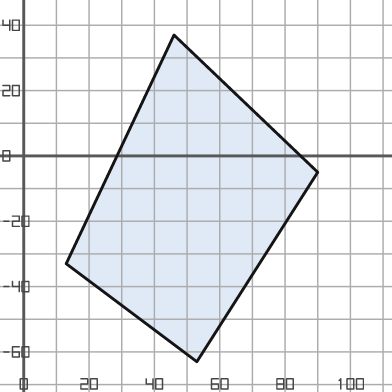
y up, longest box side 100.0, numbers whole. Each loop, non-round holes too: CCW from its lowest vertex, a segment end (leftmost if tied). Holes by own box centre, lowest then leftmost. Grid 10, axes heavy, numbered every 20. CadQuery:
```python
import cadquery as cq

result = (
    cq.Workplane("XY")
    .moveTo(53.0, -63.0)
    .lineTo(90.0, -5.0)
    .lineTo(46.0, 37.0)
    .lineTo(13.0, -33.0)
    .close()
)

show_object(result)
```